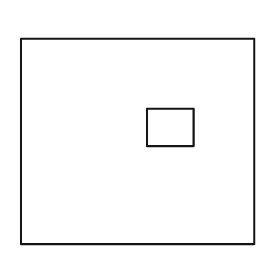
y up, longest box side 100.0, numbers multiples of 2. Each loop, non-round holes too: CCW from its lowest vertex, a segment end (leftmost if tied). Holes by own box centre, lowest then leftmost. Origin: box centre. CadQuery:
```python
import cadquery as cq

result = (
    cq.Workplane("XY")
    .moveTo(-50.0, -44.0)
    .lineTo(50.0, -44.0)
    .lineTo(50.0, 44.0)
    .lineTo(-50.0, 44.0)
    .close()
    .moveTo(4.0, -2.0)
    .lineTo(24.0, -2.0)
    .lineTo(24.0, 14.0)
    .lineTo(4.0, 14.0)
    .close()
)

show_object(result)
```